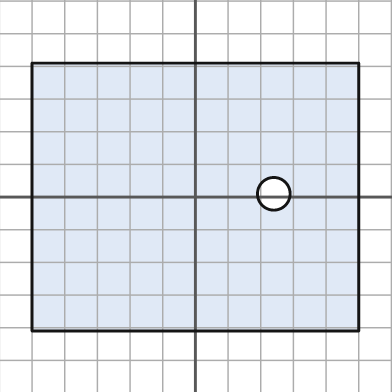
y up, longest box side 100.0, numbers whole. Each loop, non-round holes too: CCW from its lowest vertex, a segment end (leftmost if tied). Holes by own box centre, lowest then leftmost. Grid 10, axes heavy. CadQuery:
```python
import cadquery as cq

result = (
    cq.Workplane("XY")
    .moveTo(-50.0, -41.0)
    .lineTo(50.0, -41.0)
    .lineTo(50.0, 41.0)
    .lineTo(-50.0, 41.0)
    .close()
    .moveTo(24.0, 1.0)
    .circle(5.0)
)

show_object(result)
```